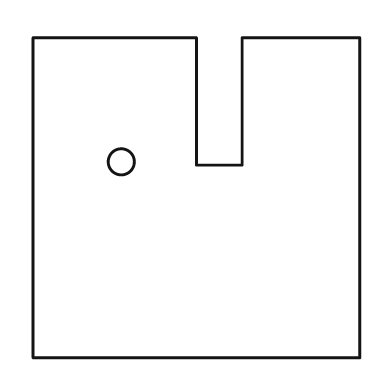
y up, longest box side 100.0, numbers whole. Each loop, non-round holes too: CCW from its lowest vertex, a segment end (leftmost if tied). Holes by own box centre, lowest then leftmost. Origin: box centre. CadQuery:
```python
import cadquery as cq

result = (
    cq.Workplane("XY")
    .moveTo(-50.0, -49.0)
    .lineTo(50.0, -49.0)
    .lineTo(50.0, 49.0)
    .lineTo(14.0, 49.0)
    .lineTo(14.0, 10.0)
    .lineTo(0.0, 10.0)
    .lineTo(0.0, 49.0)
    .lineTo(-50.0, 49.0)
    .close()
    .moveTo(-23.0, 11.0)
    .circle(4.0)
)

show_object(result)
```